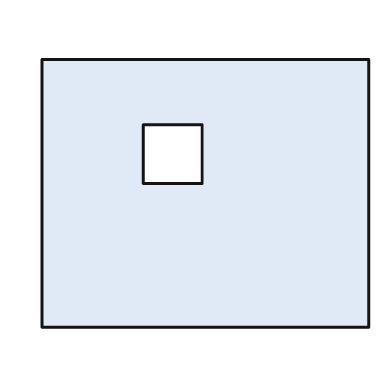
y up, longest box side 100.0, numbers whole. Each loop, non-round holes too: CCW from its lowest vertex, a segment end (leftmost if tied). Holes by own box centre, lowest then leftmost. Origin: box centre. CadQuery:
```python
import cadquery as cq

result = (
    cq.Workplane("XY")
    .moveTo(-50.0, -41.0)
    .lineTo(50.0, -41.0)
    .lineTo(50.0, 41.0)
    .lineTo(-50.0, 41.0)
    .close()
    .moveTo(-19.0, 3.0)
    .lineTo(-1.0, 3.0)
    .lineTo(-1.0, 21.0)
    .lineTo(-19.0, 21.0)
    .close()
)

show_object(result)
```